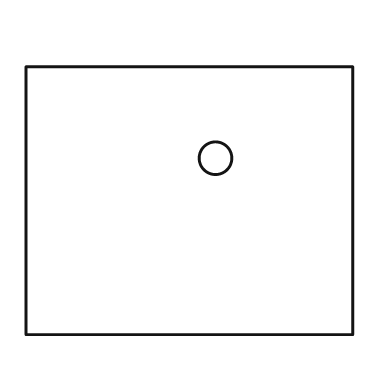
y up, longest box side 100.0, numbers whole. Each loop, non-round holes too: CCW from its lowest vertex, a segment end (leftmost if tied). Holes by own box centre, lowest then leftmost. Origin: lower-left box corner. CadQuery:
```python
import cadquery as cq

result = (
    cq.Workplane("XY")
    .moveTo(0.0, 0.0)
    .lineTo(100.0, 0.0)
    .lineTo(100.0, 82.0)
    .lineTo(0.0, 82.0)
    .close()
    .moveTo(58.0, 54.0)
    .circle(5.0)
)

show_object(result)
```